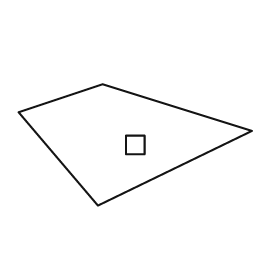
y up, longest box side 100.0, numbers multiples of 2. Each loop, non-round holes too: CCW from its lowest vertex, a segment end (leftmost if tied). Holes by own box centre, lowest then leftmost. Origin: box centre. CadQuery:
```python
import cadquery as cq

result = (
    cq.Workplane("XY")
    .moveTo(-16.0, -26.0)
    .lineTo(50.0, 6.0)
    .lineTo(-14.0, 26.0)
    .lineTo(-50.0, 14.0)
    .close()
    .moveTo(-4.0, -4.0)
    .lineTo(4.0, -4.0)
    .lineTo(4.0, 4.0)
    .lineTo(-4.0, 4.0)
    .close()
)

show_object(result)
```